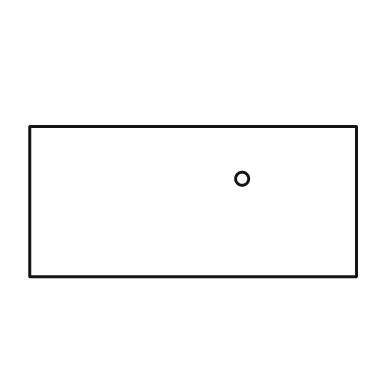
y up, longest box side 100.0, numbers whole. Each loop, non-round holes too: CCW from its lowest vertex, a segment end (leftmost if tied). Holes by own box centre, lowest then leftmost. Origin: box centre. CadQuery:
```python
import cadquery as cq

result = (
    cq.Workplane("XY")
    .moveTo(-50.0, -23.0)
    .lineTo(50.0, -23.0)
    .lineTo(50.0, 23.0)
    .lineTo(-50.0, 23.0)
    .close()
    .moveTo(15.0, 7.0)
    .circle(2.0)
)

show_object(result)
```